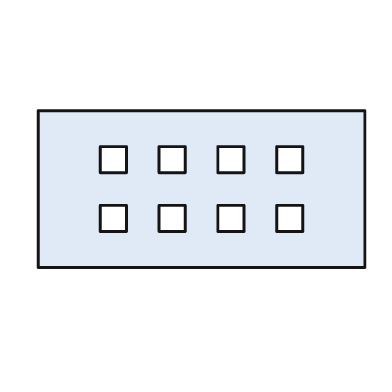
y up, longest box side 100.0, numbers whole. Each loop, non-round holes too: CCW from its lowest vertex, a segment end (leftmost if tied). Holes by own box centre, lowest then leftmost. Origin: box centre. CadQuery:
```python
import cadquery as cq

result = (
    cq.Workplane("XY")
    .moveTo(-50.0, -24.0)
    .lineTo(50.0, -24.0)
    .lineTo(50.0, 24.0)
    .lineTo(-50.0, 24.0)
    .close()
    .moveTo(-31.0, -13.0)
    .lineTo(-23.0, -13.0)
    .lineTo(-23.0, -5.0)
    .lineTo(-31.0, -5.0)
    .close()
    .moveTo(-13.0, -13.0)
    .lineTo(-5.0, -13.0)
    .lineTo(-5.0, -5.0)
    .lineTo(-13.0, -5.0)
    .close()
    .moveTo(5.0, -13.0)
    .lineTo(13.0, -13.0)
    .lineTo(13.0, -5.0)
    .lineTo(5.0, -5.0)
    .close()
    .moveTo(23.0, -13.0)
    .lineTo(31.0, -13.0)
    .lineTo(31.0, -5.0)
    .lineTo(23.0, -5.0)
    .close()
    .moveTo(-31.0, 5.0)
    .lineTo(-23.0, 5.0)
    .lineTo(-23.0, 13.0)
    .lineTo(-31.0, 13.0)
    .close()
    .moveTo(-13.0, 5.0)
    .lineTo(-5.0, 5.0)
    .lineTo(-5.0, 13.0)
    .lineTo(-13.0, 13.0)
    .close()
    .moveTo(5.0, 5.0)
    .lineTo(13.0, 5.0)
    .lineTo(13.0, 13.0)
    .lineTo(5.0, 13.0)
    .close()
    .moveTo(23.0, 5.0)
    .lineTo(31.0, 5.0)
    .lineTo(31.0, 13.0)
    .lineTo(23.0, 13.0)
    .close()
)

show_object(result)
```